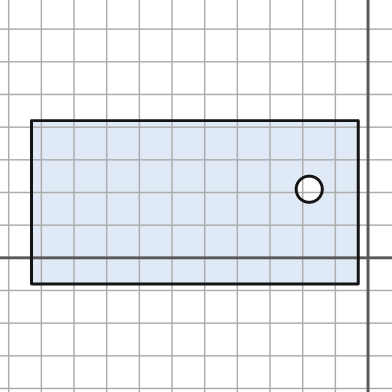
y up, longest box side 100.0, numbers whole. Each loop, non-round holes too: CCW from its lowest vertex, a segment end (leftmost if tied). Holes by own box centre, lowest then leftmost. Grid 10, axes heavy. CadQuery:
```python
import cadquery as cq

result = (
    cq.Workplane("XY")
    .moveTo(-103.0, -8.0)
    .lineTo(-3.0, -8.0)
    .lineTo(-3.0, 42.0)
    .lineTo(-103.0, 42.0)
    .close()
    .moveTo(-18.0, 21.0)
    .circle(4.0)
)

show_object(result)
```